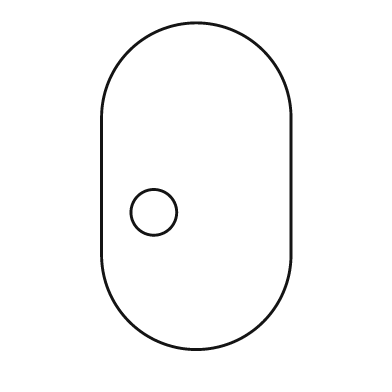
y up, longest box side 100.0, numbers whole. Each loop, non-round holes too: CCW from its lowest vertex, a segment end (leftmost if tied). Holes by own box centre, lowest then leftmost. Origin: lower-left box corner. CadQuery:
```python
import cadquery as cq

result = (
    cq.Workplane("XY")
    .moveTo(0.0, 29.0)
    .threePointArc((29.0, 0.0), (58.0, 29.0))
    .lineTo(58.0, 71.0)
    .threePointArc((29.0, 100.0), (0.0, 71.0))
    .close()
    .moveTo(16.0, 42.0)
    .circle(7.0)
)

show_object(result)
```